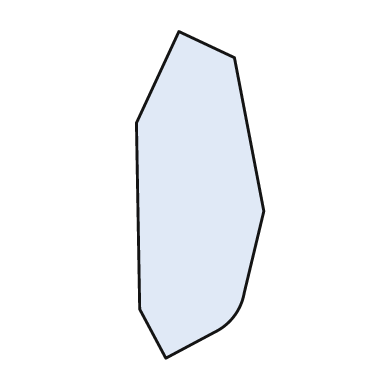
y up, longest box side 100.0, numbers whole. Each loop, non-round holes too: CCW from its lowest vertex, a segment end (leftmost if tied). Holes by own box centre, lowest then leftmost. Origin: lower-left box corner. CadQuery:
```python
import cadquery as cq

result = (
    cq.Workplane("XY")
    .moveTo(9.0, 0.0)
    .lineTo(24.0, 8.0)
    .threePointArc((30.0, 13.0), (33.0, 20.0))
    .lineTo(39.0, 45.0)
    .lineTo(30.0, 92.0)
    .lineTo(13.0, 100.0)
    .lineTo(0.0, 72.0)
    .lineTo(1.0, 15.0)
    .close()
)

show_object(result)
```